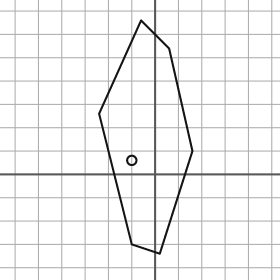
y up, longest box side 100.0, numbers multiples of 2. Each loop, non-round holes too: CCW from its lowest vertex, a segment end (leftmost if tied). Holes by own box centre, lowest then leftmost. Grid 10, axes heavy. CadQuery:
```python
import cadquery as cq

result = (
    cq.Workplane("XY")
    .moveTo(2.0, -34.0)
    .lineTo(16.0, 10.0)
    .lineTo(6.0, 54.0)
    .lineTo(-6.0, 66.0)
    .lineTo(-24.0, 26.0)
    .lineTo(-10.0, -30.0)
    .close()
    .moveTo(-10.0, 6.0)
    .circle(2.0)
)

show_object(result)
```